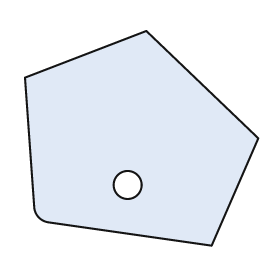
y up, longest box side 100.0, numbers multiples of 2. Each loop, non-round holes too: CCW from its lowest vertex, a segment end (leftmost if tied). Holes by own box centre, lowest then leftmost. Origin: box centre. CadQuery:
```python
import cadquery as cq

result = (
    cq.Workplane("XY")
    .moveTo(30.0, -46.0)
    .lineTo(50.0, 0.0)
    .lineTo(2.0, 46.0)
    .lineTo(-50.0, 26.0)
    .lineTo(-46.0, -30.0)
    .threePointArc((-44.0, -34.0), (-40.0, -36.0))
    .close()
    .moveTo(-6.0, -20.0)
    .circle(6.0)
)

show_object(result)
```